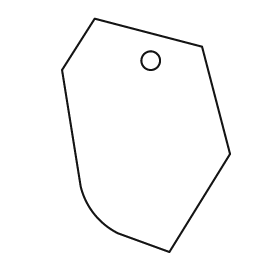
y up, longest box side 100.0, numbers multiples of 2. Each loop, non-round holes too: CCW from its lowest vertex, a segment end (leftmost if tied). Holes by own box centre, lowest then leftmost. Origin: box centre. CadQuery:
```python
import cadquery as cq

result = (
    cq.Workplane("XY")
    .moveTo(10.0, -50.0)
    .lineTo(36.0, -8.0)
    .lineTo(24.0, 38.0)
    .lineTo(-22.0, 50.0)
    .lineTo(-36.0, 28.0)
    .lineTo(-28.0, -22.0)
    .threePointArc((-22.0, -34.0), (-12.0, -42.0))
    .close()
    .moveTo(2.0, 32.0)
    .circle(4.0)
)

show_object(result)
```